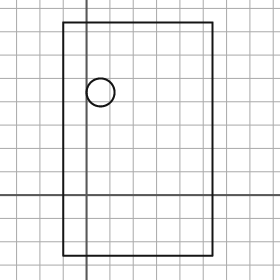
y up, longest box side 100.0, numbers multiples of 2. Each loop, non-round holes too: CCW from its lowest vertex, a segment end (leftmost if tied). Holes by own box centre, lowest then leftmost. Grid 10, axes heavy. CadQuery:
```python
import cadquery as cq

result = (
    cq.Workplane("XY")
    .moveTo(-10.0, -26.0)
    .lineTo(54.0, -26.0)
    .lineTo(54.0, 74.0)
    .lineTo(-10.0, 74.0)
    .close()
    .moveTo(6.0, 44.0)
    .circle(6.0)
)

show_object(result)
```